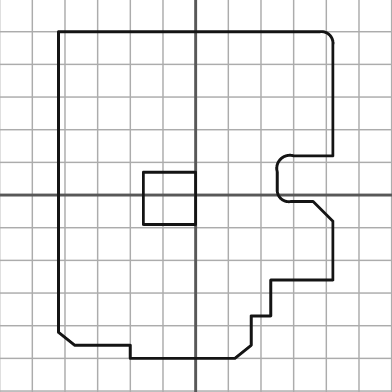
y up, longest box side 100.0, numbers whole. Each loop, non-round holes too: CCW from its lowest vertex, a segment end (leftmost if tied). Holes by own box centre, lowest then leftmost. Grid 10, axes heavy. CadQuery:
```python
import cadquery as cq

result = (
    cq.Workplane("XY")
    .moveTo(-20.0, -50.0)
    .lineTo(12.0, -50.0)
    .lineTo(17.0, -46.0)
    .lineTo(17.0, -37.0)
    .lineTo(23.0, -37.0)
    .lineTo(23.0, -26.0)
    .lineTo(42.0, -26.0)
    .lineTo(42.0, -8.0)
    .lineTo(36.0, -2.0)
    .lineTo(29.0, -2.0)
    .threePointArc((26.0, -1.0), (25.0, 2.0))
    .lineTo(25.0, 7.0)
    .threePointArc((26.0, 11.0), (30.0, 12.0))
    .lineTo(42.0, 12.0)
    .lineTo(42.0, 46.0)
    .threePointArc((41.0, 49.0), (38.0, 50.0))
    .lineTo(-42.0, 50.0)
    .lineTo(-42.0, -42.0)
    .lineTo(-37.0, -46.0)
    .lineTo(-20.0, -46.0)
    .close()
    .moveTo(-16.0, -9.0)
    .lineTo(0.0, -9.0)
    .lineTo(0.0, 7.0)
    .lineTo(-16.0, 7.0)
    .close()
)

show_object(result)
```